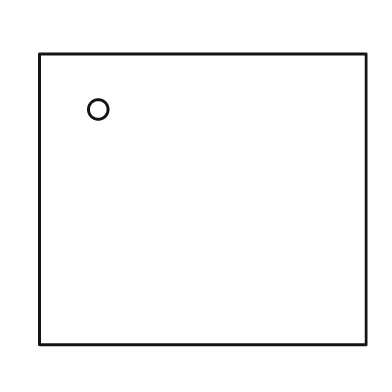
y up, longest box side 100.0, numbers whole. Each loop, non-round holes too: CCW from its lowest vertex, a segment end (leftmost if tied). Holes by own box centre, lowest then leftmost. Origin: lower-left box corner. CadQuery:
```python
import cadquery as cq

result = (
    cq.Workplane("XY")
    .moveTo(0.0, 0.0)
    .lineTo(100.0, 0.0)
    .lineTo(100.0, 89.0)
    .lineTo(0.0, 89.0)
    .close()
    .moveTo(18.0, 72.0)
    .circle(3.0)
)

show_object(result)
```